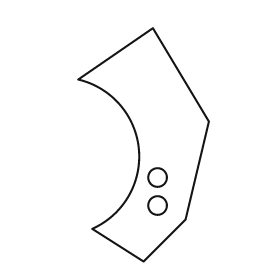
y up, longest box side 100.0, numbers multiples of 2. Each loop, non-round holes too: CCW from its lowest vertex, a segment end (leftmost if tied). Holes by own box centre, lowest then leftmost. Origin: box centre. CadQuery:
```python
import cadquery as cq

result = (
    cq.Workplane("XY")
    .moveTo(0.0, -50.0)
    .lineTo(18.0, -32.0)
    .lineTo(28.0, 10.0)
    .lineTo(4.0, 50.0)
    .lineTo(-28.0, 28.0)
    .threePointArc((-2.0, -2.0), (-22.0, -36.0))
    .close()
    .moveTo(6.0, -26.0)
    .circle(4.0)
    .moveTo(6.0, -14.0)
    .circle(4.0)
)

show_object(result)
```